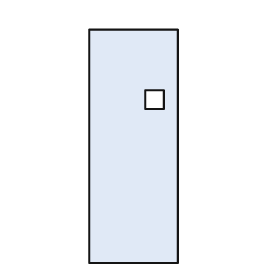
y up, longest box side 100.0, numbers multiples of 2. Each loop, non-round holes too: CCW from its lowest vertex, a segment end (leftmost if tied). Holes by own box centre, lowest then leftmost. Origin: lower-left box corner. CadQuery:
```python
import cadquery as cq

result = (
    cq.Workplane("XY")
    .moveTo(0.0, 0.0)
    .lineTo(38.0, 0.0)
    .lineTo(38.0, 100.0)
    .lineTo(0.0, 100.0)
    .close()
    .moveTo(24.0, 66.0)
    .lineTo(32.0, 66.0)
    .lineTo(32.0, 74.0)
    .lineTo(24.0, 74.0)
    .close()
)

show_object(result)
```